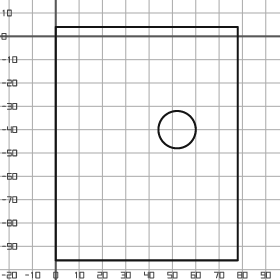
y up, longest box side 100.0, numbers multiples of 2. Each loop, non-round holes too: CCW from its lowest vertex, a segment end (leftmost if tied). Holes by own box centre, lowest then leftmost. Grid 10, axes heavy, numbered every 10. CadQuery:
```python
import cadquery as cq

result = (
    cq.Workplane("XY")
    .moveTo(0.0, -96.0)
    .lineTo(78.0, -96.0)
    .lineTo(78.0, 4.0)
    .lineTo(0.0, 4.0)
    .close()
    .moveTo(52.0, -40.0)
    .circle(8.0)
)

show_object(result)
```